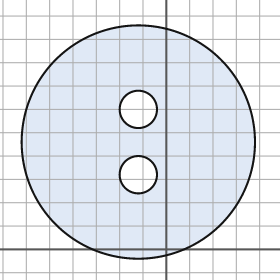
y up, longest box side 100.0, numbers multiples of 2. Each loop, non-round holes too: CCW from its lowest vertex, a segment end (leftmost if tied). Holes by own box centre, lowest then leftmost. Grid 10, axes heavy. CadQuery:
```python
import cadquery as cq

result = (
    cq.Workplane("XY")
    .moveTo(-12.0, 46.0)
    .circle(50.0)
    .moveTo(-12.0, 32.0)
    .circle(8.0)
    .moveTo(-12.0, 60.0)
    .circle(8.0)
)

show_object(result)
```